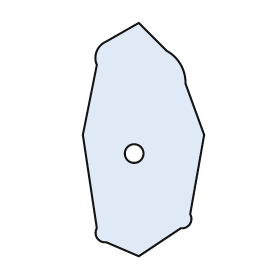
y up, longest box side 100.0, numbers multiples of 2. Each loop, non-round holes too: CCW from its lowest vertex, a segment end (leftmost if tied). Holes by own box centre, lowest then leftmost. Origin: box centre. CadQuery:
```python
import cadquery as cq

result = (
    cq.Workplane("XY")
    .moveTo(-2.0, -50.0)
    .lineTo(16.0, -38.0)
    .threePointArc((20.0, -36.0), (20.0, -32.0))
    .lineTo(26.0, 2.0)
    .lineTo(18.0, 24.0)
    .threePointArc((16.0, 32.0), (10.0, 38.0))
    .lineTo(-2.0, 50.0)
    .lineTo(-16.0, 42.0)
    .threePointArc((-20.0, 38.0), (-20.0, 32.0))
    .lineTo(-26.0, 2.0)
    .lineTo(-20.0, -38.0)
    .threePointArc((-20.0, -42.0), (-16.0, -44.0))
    .close()
    .moveTo(-4.0, -6.0)
    .circle(4.0)
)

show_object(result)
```